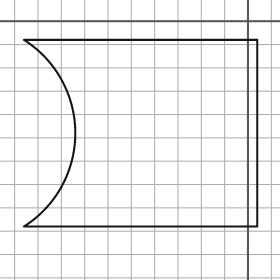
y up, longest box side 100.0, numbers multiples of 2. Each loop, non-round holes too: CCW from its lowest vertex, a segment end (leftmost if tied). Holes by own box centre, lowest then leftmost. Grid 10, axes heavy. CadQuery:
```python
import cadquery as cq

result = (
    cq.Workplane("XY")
    .moveTo(-96.0, -88.0)
    .lineTo(4.0, -88.0)
    .lineTo(4.0, -8.0)
    .lineTo(-96.0, -8.0)
    .threePointArc((-74.0, -48.0), (-96.0, -88.0))
    .close()
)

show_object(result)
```